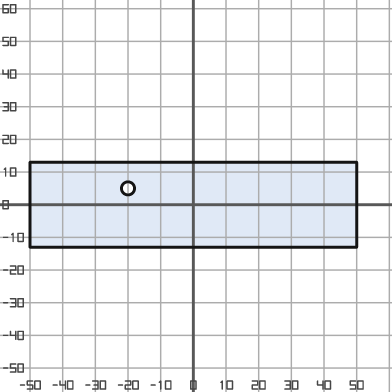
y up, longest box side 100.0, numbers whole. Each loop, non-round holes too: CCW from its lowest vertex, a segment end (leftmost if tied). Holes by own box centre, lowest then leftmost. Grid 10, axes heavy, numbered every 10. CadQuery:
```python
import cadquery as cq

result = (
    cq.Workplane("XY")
    .moveTo(-50.0, -13.0)
    .lineTo(50.0, -13.0)
    .lineTo(50.0, 13.0)
    .lineTo(-50.0, 13.0)
    .close()
    .moveTo(-20.0, 5.0)
    .circle(2.0)
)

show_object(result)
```